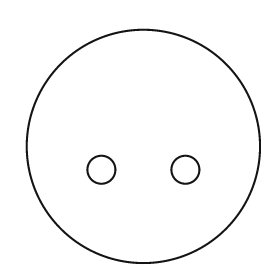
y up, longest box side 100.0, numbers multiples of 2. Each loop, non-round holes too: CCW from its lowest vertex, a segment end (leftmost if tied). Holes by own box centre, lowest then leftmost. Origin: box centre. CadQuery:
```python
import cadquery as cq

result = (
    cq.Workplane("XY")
    .moveTo(0.0, 0.0)
    .circle(50.0)
    .moveTo(-18.0, -10.0)
    .circle(6.0)
    .moveTo(18.0, -10.0)
    .circle(6.0)
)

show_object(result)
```